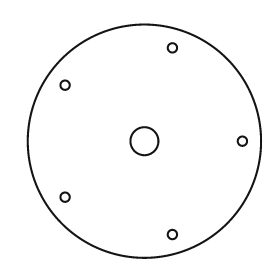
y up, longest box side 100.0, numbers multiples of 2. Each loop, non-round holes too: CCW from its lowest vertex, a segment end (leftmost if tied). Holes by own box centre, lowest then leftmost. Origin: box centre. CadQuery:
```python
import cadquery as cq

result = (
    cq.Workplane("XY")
    .moveTo(0.0, 0.0)
    .circle(50.0)
    .moveTo(12.0, -40.0)
    .circle(2.0)
    .moveTo(-34.0, -24.0)
    .circle(2.0)
    .moveTo(0.0, 0.0)
    .circle(6.0)
    .moveTo(42.0, 0.0)
    .circle(2.0)
    .moveTo(-34.0, 24.0)
    .circle(2.0)
    .moveTo(12.0, 40.0)
    .circle(2.0)
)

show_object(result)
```